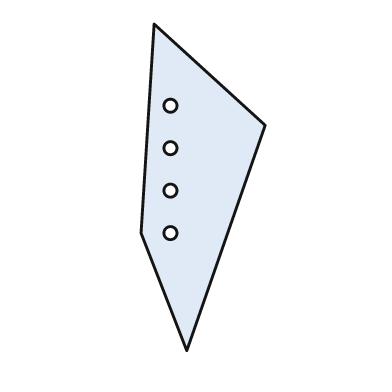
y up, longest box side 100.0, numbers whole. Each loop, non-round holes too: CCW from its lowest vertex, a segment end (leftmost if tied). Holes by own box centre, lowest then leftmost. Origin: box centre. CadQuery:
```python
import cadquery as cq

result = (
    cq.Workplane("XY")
    .moveTo(-5.0, -50.0)
    .lineTo(19.0, 19.0)
    .lineTo(-15.0, 50.0)
    .lineTo(-19.0, -14.0)
    .close()
    .moveTo(-10.0, -14.0)
    .circle(2.0)
    .moveTo(-10.0, -1.0)
    .circle(2.0)
    .moveTo(-10.0, 12.0)
    .circle(2.0)
    .moveTo(-10.0, 25.0)
    .circle(2.0)
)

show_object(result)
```